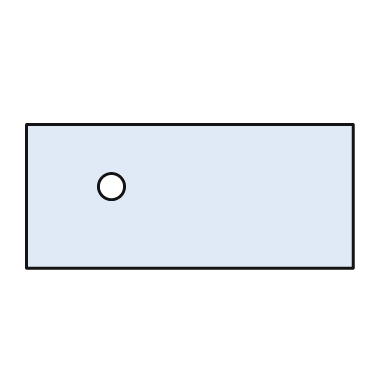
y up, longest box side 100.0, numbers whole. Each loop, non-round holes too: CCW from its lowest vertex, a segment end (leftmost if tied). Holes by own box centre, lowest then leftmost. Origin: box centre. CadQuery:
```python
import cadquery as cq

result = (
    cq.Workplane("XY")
    .moveTo(-50.0, -22.0)
    .lineTo(50.0, -22.0)
    .lineTo(50.0, 22.0)
    .lineTo(-50.0, 22.0)
    .close()
    .moveTo(-24.0, 3.0)
    .circle(4.0)
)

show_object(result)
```